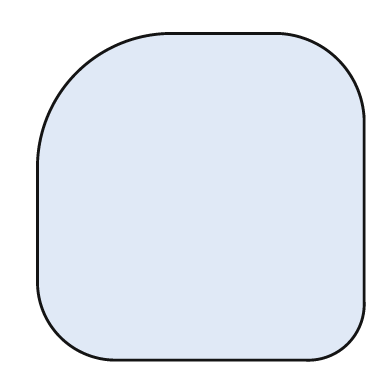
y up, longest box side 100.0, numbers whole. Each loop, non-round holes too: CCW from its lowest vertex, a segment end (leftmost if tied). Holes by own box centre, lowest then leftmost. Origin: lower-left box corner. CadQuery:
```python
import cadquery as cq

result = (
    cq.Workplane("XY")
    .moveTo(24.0, 0.0)
    .lineTo(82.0, 0.0)
    .threePointArc((95.0, 5.0), (100.0, 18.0))
    .lineTo(100.0, 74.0)
    .threePointArc((92.0, 92.0), (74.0, 100.0))
    .lineTo(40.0, 100.0)
    .threePointArc((12.0, 88.0), (0.0, 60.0))
    .lineTo(0.0, 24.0)
    .threePointArc((7.0, 7.0), (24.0, 0.0))
    .close()
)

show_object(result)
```